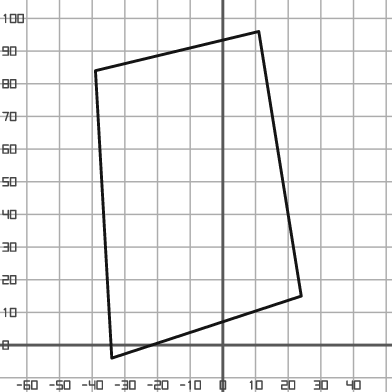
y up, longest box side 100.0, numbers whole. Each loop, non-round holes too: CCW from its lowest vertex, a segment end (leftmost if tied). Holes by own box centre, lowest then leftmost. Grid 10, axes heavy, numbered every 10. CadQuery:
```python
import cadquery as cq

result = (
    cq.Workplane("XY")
    .moveTo(-34.0, -4.0)
    .lineTo(24.0, 15.0)
    .lineTo(11.0, 96.0)
    .lineTo(-39.0, 84.0)
    .close()
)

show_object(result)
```